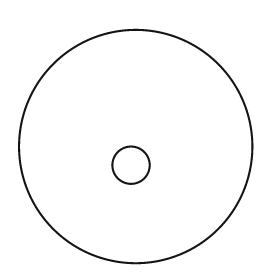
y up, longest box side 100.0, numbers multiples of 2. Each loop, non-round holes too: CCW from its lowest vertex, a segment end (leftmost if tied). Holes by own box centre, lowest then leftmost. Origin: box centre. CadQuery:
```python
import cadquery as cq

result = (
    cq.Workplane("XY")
    .moveTo(0.0, 0.0)
    .circle(50.0)
    .moveTo(-2.0, -8.0)
    .circle(8.0)
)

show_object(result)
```